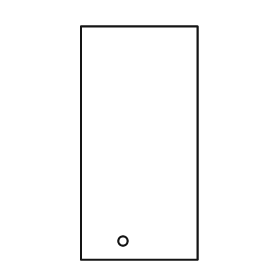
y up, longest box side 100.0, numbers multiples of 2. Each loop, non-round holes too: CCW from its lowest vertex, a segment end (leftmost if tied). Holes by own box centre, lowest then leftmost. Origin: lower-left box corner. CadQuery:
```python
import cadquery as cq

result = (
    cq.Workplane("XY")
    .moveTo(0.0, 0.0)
    .lineTo(50.0, 0.0)
    .lineTo(50.0, 100.0)
    .lineTo(0.0, 100.0)
    .close()
    .moveTo(18.0, 8.0)
    .circle(2.0)
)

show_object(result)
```